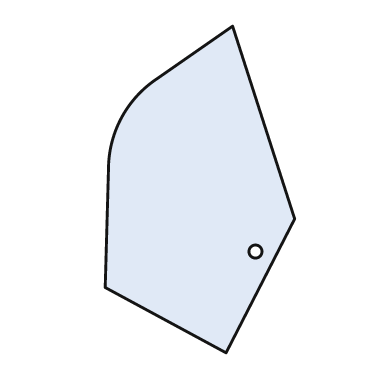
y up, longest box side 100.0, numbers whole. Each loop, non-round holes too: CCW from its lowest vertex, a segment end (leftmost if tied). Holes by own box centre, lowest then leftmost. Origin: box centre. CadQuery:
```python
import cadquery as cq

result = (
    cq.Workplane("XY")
    .moveTo(8.0, -50.0)
    .lineTo(29.0, -9.0)
    .lineTo(10.0, 50.0)
    .lineTo(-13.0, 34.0)
    .threePointArc((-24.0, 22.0), (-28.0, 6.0))
    .lineTo(-29.0, -30.0)
    .close()
    .moveTo(17.0, -19.0)
    .circle(2.0)
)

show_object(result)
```